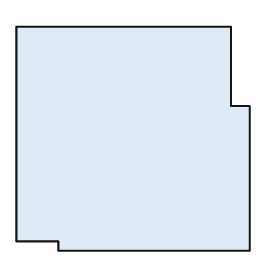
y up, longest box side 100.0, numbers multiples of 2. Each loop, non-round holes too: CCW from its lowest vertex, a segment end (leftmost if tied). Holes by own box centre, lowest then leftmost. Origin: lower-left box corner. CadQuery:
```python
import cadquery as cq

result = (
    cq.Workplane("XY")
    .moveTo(18.0, 0.0)
    .lineTo(100.0, 0.0)
    .lineTo(100.0, 62.0)
    .lineTo(92.0, 62.0)
    .lineTo(92.0, 96.0)
    .lineTo(0.0, 96.0)
    .lineTo(0.0, 4.0)
    .lineTo(18.0, 4.0)
    .close()
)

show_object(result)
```